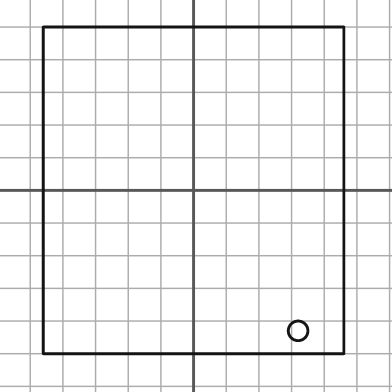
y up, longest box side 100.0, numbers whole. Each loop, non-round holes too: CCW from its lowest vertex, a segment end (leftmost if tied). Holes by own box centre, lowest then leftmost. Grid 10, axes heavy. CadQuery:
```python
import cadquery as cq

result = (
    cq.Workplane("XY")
    .moveTo(-46.0, -50.0)
    .lineTo(46.0, -50.0)
    .lineTo(46.0, 50.0)
    .lineTo(-46.0, 50.0)
    .close()
    .moveTo(32.0, -43.0)
    .circle(3.0)
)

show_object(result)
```